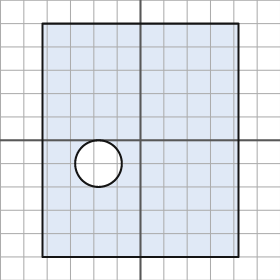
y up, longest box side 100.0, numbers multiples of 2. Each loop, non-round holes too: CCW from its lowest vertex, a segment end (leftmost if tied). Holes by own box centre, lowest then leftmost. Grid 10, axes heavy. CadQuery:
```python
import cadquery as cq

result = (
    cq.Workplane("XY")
    .moveTo(-42.0, -50.0)
    .lineTo(42.0, -50.0)
    .lineTo(42.0, 50.0)
    .lineTo(-42.0, 50.0)
    .close()
    .moveTo(-18.0, -10.0)
    .circle(10.0)
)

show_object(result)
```